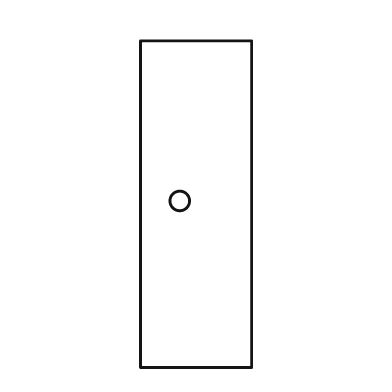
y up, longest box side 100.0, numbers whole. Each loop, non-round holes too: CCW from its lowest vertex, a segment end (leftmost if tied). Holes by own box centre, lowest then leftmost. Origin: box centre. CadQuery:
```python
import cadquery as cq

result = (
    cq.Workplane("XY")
    .moveTo(-17.0, -50.0)
    .lineTo(17.0, -50.0)
    .lineTo(17.0, 50.0)
    .lineTo(-17.0, 50.0)
    .close()
    .moveTo(-5.0, 1.0)
    .circle(3.0)
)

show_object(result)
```